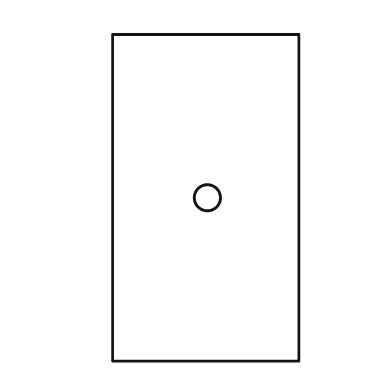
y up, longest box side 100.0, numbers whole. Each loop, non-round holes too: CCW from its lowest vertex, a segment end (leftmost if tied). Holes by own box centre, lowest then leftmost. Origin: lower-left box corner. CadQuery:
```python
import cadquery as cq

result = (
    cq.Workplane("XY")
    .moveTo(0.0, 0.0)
    .lineTo(57.0, 0.0)
    .lineTo(57.0, 100.0)
    .lineTo(0.0, 100.0)
    .close()
    .moveTo(29.0, 50.0)
    .circle(4.0)
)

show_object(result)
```